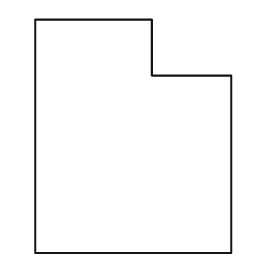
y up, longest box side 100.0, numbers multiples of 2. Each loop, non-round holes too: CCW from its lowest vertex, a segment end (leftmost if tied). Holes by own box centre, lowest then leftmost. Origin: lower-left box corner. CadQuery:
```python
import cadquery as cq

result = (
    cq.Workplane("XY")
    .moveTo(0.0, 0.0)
    .lineTo(84.0, 0.0)
    .lineTo(84.0, 76.0)
    .lineTo(50.0, 76.0)
    .lineTo(50.0, 100.0)
    .lineTo(0.0, 100.0)
    .close()
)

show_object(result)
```